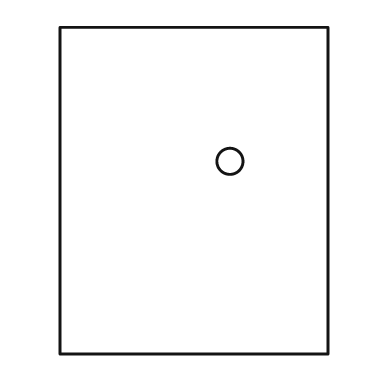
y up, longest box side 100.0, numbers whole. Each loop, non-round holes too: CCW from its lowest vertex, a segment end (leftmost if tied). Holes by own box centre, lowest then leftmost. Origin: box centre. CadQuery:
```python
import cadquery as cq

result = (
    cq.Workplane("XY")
    .moveTo(-41.0, -50.0)
    .lineTo(41.0, -50.0)
    .lineTo(41.0, 50.0)
    .lineTo(-41.0, 50.0)
    .close()
    .moveTo(11.0, 9.0)
    .circle(4.0)
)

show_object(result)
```